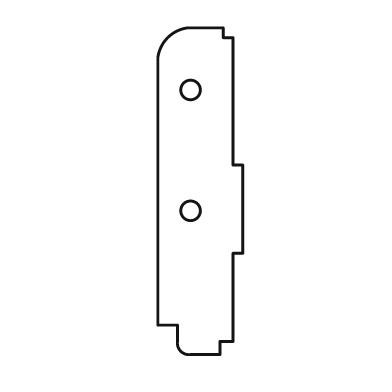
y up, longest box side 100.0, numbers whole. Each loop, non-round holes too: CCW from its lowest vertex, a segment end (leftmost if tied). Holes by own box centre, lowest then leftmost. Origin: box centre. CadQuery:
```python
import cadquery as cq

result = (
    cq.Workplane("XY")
    .moveTo(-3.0, -50.0)
    .lineTo(6.0, -50.0)
    .lineTo(6.0, -46.0)
    .lineTo(10.0, -46.0)
    .lineTo(10.0, -19.0)
    .lineTo(13.0, -19.0)
    .lineTo(13.0, 8.0)
    .lineTo(10.0, 8.0)
    .lineTo(10.0, 47.0)
    .lineTo(7.0, 47.0)
    .lineTo(7.0, 50.0)
    .lineTo(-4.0, 50.0)
    .threePointArc((-10.0, 47.0), (-13.0, 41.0))
    .lineTo(-13.0, -41.0)
    .lineTo(-7.0, -41.0)
    .lineTo(-7.0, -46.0)
    .threePointArc((-6.0, -49.0), (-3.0, -50.0))
    .close()
    .moveTo(-3.0, -6.0)
    .circle(3.0)
    .moveTo(-3.0, 31.0)
    .circle(3.0)
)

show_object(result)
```